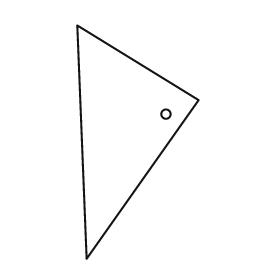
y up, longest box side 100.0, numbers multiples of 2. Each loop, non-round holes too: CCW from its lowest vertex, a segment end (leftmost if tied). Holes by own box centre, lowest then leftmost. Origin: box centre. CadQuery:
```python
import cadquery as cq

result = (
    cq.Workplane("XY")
    .moveTo(-22.0, -50.0)
    .lineTo(26.0, 18.0)
    .lineTo(-26.0, 50.0)
    .close()
    .moveTo(12.0, 12.0)
    .circle(2.0)
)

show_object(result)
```